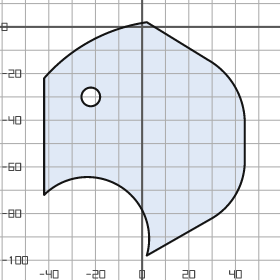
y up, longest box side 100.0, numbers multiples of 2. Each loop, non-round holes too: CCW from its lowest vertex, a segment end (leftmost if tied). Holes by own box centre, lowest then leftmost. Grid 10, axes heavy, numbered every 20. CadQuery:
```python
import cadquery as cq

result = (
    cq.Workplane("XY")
    .moveTo(2.0, -98.0)
    .lineTo(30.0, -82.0)
    .threePointArc((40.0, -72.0), (44.0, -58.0))
    .lineTo(44.0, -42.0)
    .threePointArc((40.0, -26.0), (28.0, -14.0))
    .lineTo(2.0, 2.0)
    .threePointArc((-22.0, -6.0), (-42.0, -22.0))
    .lineTo(-42.0, -72.0)
    .threePointArc((-10.0, -68.0), (2.0, -98.0))
    .close()
    .moveTo(-22.0, -30.0)
    .circle(4.0)
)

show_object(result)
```